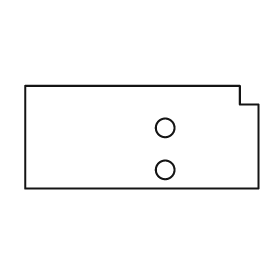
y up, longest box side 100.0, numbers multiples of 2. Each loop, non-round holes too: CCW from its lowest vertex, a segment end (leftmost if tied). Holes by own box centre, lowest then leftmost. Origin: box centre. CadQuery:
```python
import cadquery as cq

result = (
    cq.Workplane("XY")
    .moveTo(-50.0, -22.0)
    .lineTo(50.0, -22.0)
    .lineTo(50.0, 14.0)
    .lineTo(42.0, 14.0)
    .lineTo(42.0, 22.0)
    .lineTo(-50.0, 22.0)
    .close()
    .moveTo(10.0, -14.0)
    .circle(4.0)
    .moveTo(10.0, 4.0)
    .circle(4.0)
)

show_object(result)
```